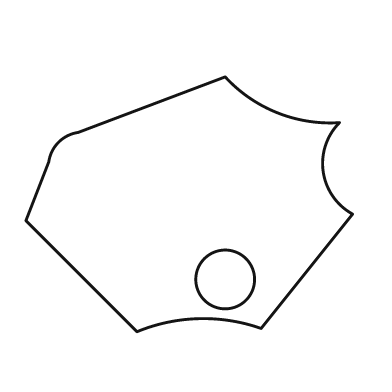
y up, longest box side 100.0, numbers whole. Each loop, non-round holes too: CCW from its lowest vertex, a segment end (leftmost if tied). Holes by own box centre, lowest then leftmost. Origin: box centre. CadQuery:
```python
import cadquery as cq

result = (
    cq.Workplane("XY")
    .moveTo(-16.0, -39.0)
    .threePointArc((3.0, -35.0), (22.0, -38.0))
    .lineTo(50.0, -3.0)
    .threePointArc((41.0, 10.0), (46.0, 25.0))
    .threePointArc((27.0, 28.0), (11.0, 39.0))
    .lineTo(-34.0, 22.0)
    .threePointArc((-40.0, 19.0), (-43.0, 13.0))
    .lineTo(-50.0, -5.0)
    .close()
    .moveTo(11.0, -23.0)
    .circle(9.0)
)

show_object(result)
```